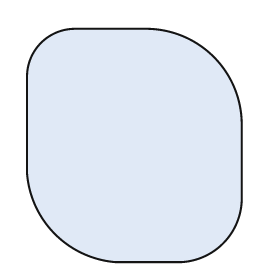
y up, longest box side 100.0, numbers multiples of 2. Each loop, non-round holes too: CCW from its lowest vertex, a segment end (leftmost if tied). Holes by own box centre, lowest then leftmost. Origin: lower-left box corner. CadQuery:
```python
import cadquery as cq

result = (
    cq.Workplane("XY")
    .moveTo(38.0, 0.0)
    .lineTo(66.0, 0.0)
    .threePointArc((84.0, 8.0), (92.0, 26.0))
    .lineTo(92.0, 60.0)
    .threePointArc((80.0, 88.0), (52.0, 100.0))
    .lineTo(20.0, 100.0)
    .threePointArc((6.0, 94.0), (0.0, 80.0))
    .lineTo(0.0, 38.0)
    .threePointArc((12.0, 12.0), (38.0, 0.0))
    .close()
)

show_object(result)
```